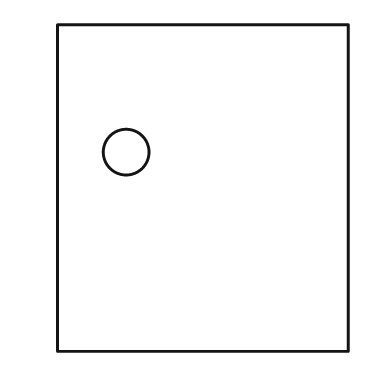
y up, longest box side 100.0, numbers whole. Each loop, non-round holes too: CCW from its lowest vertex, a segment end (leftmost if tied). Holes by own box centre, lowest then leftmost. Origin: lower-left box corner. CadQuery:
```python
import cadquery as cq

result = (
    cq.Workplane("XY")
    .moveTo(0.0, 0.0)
    .lineTo(89.0, 0.0)
    .lineTo(89.0, 100.0)
    .lineTo(0.0, 100.0)
    .close()
    .moveTo(21.0, 61.0)
    .circle(7.0)
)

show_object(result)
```